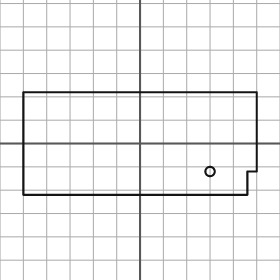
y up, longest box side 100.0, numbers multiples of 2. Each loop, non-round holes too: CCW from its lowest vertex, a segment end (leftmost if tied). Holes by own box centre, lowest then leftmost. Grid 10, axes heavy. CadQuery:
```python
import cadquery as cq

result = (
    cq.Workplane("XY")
    .moveTo(-50.0, -22.0)
    .lineTo(46.0, -22.0)
    .lineTo(46.0, -12.0)
    .lineTo(50.0, -12.0)
    .lineTo(50.0, 22.0)
    .lineTo(-50.0, 22.0)
    .close()
    .moveTo(30.0, -12.0)
    .circle(2.0)
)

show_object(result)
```